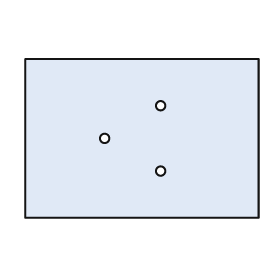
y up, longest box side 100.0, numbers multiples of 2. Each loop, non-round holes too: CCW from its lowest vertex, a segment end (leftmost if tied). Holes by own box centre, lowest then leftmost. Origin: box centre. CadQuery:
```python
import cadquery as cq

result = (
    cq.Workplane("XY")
    .moveTo(-50.0, -34.0)
    .lineTo(50.0, -34.0)
    .lineTo(50.0, 34.0)
    .lineTo(-50.0, 34.0)
    .close()
    .moveTo(8.0, -14.0)
    .circle(2.0)
    .moveTo(-16.0, 0.0)
    .circle(2.0)
    .moveTo(8.0, 14.0)
    .circle(2.0)
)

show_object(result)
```